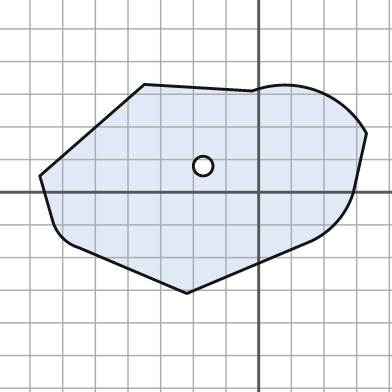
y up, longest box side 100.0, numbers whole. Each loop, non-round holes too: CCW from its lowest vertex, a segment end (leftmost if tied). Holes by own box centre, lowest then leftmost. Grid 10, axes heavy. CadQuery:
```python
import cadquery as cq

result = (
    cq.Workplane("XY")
    .moveTo(-22.0, -31.0)
    .lineTo(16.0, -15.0)
    .threePointArc((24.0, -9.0), (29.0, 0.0))
    .lineTo(33.0, 18.0)
    .threePointArc((18.0, 31.0), (-2.0, 31.0))
    .lineTo(-35.0, 33.0)
    .lineTo(-67.0, 5.0)
    .lineTo(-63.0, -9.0)
    .threePointArc((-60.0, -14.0), (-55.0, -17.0))
    .close()
    .moveTo(-17.0, 8.0)
    .circle(3.0)
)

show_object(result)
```